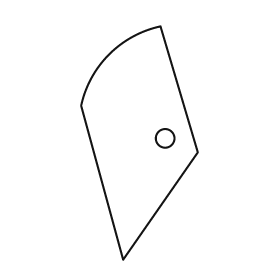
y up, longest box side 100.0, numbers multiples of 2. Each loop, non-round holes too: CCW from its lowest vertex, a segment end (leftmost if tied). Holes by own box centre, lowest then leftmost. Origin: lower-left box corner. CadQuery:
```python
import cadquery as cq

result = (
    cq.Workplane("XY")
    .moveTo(18.0, 0.0)
    .lineTo(50.0, 46.0)
    .lineTo(34.0, 100.0)
    .threePointArc((12.0, 88.0), (0.0, 66.0))
    .close()
    .moveTo(36.0, 52.0)
    .circle(4.0)
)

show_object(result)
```